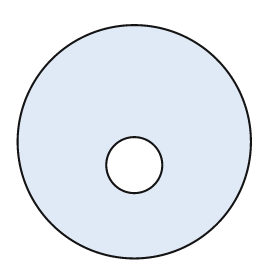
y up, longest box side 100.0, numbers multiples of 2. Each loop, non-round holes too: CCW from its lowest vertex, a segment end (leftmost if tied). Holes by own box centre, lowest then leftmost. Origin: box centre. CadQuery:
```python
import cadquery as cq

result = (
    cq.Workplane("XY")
    .moveTo(0.0, 0.0)
    .circle(50.0)
    .moveTo(0.0, -10.0)
    .circle(12.0)
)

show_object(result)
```